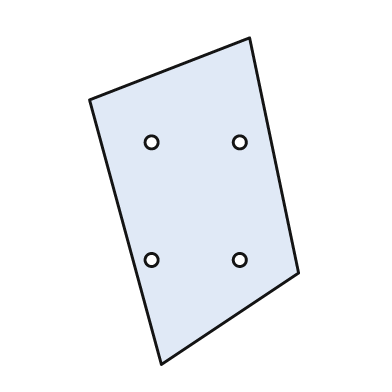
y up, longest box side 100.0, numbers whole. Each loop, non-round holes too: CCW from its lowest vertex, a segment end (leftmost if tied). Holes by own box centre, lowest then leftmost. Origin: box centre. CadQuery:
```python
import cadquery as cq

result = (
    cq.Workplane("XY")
    .moveTo(-10.0, -50.0)
    .lineTo(32.0, -22.0)
    .lineTo(17.0, 50.0)
    .lineTo(-32.0, 31.0)
    .close()
    .moveTo(-13.0, -18.0)
    .circle(2.0)
    .moveTo(14.0, -18.0)
    .circle(2.0)
    .moveTo(-13.0, 18.0)
    .circle(2.0)
    .moveTo(14.0, 18.0)
    .circle(2.0)
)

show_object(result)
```